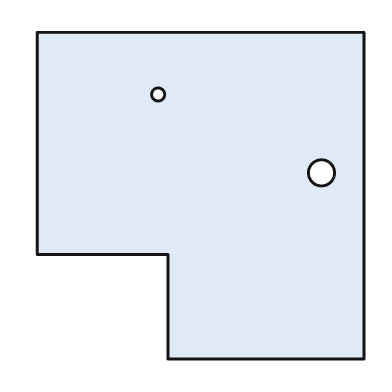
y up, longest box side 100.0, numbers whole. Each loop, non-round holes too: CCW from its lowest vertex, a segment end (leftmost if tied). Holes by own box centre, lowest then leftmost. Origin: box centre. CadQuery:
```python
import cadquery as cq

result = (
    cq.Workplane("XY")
    .moveTo(-10.0, -50.0)
    .lineTo(50.0, -50.0)
    .lineTo(50.0, 50.0)
    .lineTo(-50.0, 50.0)
    .lineTo(-50.0, -18.0)
    .lineTo(-10.0, -18.0)
    .close()
    .moveTo(37.0, 7.0)
    .circle(4.0)
    .moveTo(-13.0, 31.0)
    .circle(2.0)
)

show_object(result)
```